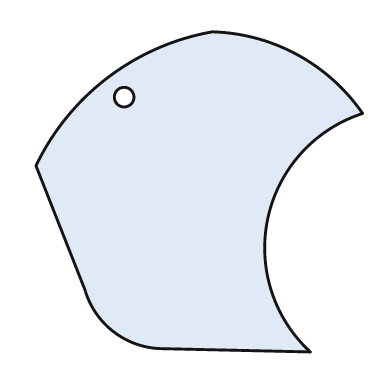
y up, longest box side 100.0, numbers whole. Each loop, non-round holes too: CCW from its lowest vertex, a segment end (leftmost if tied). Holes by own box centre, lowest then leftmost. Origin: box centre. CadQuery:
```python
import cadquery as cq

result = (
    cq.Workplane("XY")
    .moveTo(34.0, -49.0)
    .threePointArc((21.0, -8.0), (50.0, 24.0))
    .threePointArc((30.0, 42.0), (4.0, 49.0))
    .threePointArc((-28.0, 35.0), (-50.0, 8.0))
    .lineTo(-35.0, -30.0)
    .threePointArc((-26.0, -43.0), (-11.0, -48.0))
    .close()
    .moveTo(-23.0, 29.0)
    .circle(3.0)
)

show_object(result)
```